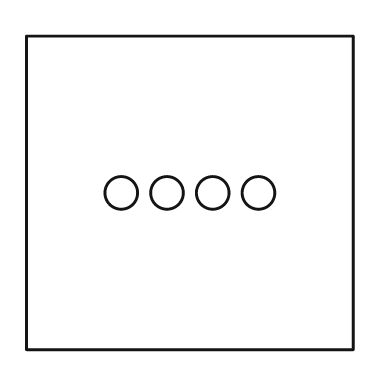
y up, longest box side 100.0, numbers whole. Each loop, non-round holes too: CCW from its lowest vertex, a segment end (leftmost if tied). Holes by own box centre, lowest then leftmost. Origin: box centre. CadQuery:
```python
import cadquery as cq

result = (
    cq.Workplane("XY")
    .moveTo(-50.0, -48.0)
    .lineTo(50.0, -48.0)
    .lineTo(50.0, 48.0)
    .lineTo(-50.0, 48.0)
    .close()
    .moveTo(-21.0, 0.0)
    .circle(5.0)
    .moveTo(-7.0, 0.0)
    .circle(5.0)
    .moveTo(7.0, 0.0)
    .circle(5.0)
    .moveTo(21.0, 0.0)
    .circle(5.0)
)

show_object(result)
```